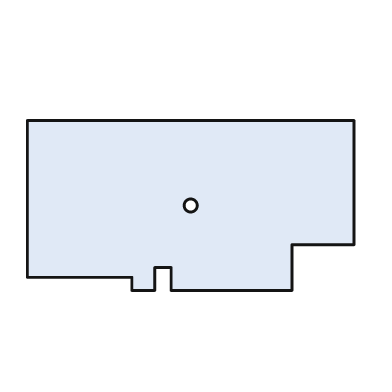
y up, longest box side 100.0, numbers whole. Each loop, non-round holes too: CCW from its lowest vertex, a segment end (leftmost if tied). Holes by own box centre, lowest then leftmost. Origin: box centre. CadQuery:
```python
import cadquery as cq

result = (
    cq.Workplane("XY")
    .moveTo(-18.0, -26.0)
    .lineTo(-11.0, -26.0)
    .lineTo(-11.0, -19.0)
    .lineTo(-6.0, -19.0)
    .lineTo(-6.0, -26.0)
    .lineTo(31.0, -26.0)
    .lineTo(31.0, -12.0)
    .lineTo(50.0, -12.0)
    .lineTo(50.0, 26.0)
    .lineTo(-50.0, 26.0)
    .lineTo(-50.0, -22.0)
    .lineTo(-18.0, -22.0)
    .close()
    .moveTo(0.0, 0.0)
    .circle(2.0)
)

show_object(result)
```